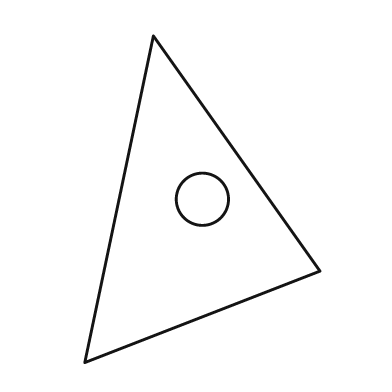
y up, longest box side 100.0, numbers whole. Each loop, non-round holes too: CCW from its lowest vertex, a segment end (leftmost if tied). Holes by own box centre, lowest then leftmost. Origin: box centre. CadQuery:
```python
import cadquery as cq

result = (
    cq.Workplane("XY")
    .moveTo(-36.0, -50.0)
    .lineTo(36.0, -22.0)
    .lineTo(-15.0, 50.0)
    .close()
    .moveTo(0.0, 0.0)
    .circle(8.0)
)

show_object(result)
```